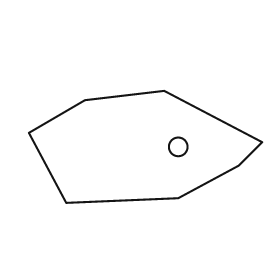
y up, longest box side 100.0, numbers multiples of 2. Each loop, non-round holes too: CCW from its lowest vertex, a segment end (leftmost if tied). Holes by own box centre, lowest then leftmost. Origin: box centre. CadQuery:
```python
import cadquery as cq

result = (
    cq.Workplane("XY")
    .moveTo(-34.0, -24.0)
    .lineTo(14.0, -22.0)
    .lineTo(40.0, -8.0)
    .lineTo(50.0, 2.0)
    .lineTo(8.0, 24.0)
    .lineTo(-26.0, 20.0)
    .lineTo(-50.0, 6.0)
    .close()
    .moveTo(14.0, 0.0)
    .circle(4.0)
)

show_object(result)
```